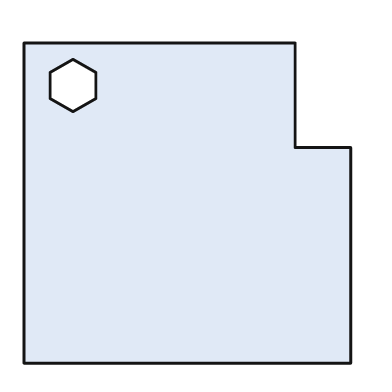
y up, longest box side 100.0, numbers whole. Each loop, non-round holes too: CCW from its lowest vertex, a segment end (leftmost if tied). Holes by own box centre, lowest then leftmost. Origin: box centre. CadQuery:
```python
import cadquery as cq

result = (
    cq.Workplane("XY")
    .moveTo(-50.0, -49.0)
    .lineTo(50.0, -49.0)
    .lineTo(50.0, 17.0)
    .lineTo(33.0, 17.0)
    .lineTo(33.0, 49.0)
    .lineTo(-50.0, 49.0)
    .close()
    .moveTo(-35.0, 28.0)
    .lineTo(-28.0, 32.0)
    .lineTo(-28.0, 40.0)
    .lineTo(-35.0, 44.0)
    .lineTo(-42.0, 40.0)
    .lineTo(-42.0, 32.0)
    .close()
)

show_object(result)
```